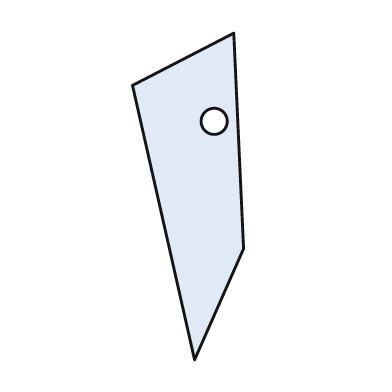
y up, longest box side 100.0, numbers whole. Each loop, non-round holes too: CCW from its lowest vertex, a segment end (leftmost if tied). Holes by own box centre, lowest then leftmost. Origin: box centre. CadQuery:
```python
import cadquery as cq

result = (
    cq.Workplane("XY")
    .moveTo(2.0, -50.0)
    .lineTo(17.0, -16.0)
    .lineTo(14.0, 50.0)
    .lineTo(-17.0, 34.0)
    .close()
    .moveTo(8.0, 23.0)
    .circle(4.0)
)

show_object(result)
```